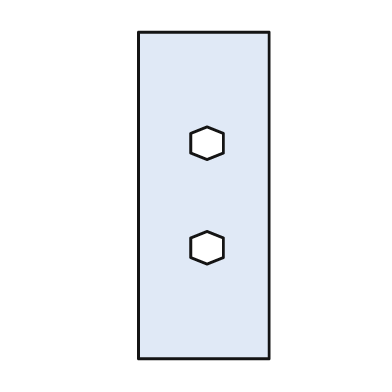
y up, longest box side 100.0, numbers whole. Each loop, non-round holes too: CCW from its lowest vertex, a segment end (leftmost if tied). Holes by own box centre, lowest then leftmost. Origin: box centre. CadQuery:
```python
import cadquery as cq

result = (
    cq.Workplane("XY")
    .moveTo(-20.0, -50.0)
    .lineTo(20.0, -50.0)
    .lineTo(20.0, 50.0)
    .lineTo(-20.0, 50.0)
    .close()
    .moveTo(1.0, -21.0)
    .lineTo(6.0, -19.0)
    .lineTo(6.0, -13.0)
    .lineTo(1.0, -11.0)
    .lineTo(-4.0, -13.0)
    .lineTo(-4.0, -19.0)
    .close()
    .moveTo(1.0, 11.0)
    .lineTo(6.0, 13.0)
    .lineTo(6.0, 19.0)
    .lineTo(1.0, 21.0)
    .lineTo(-4.0, 19.0)
    .lineTo(-4.0, 13.0)
    .close()
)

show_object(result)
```